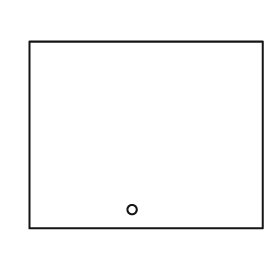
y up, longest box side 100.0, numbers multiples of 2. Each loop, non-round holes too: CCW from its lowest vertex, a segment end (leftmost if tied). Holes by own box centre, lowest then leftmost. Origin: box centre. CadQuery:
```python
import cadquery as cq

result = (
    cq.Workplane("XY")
    .moveTo(-50.0, -40.0)
    .lineTo(50.0, -40.0)
    .lineTo(50.0, 40.0)
    .lineTo(-50.0, 40.0)
    .close()
    .moveTo(-6.0, -32.0)
    .circle(2.0)
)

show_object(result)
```